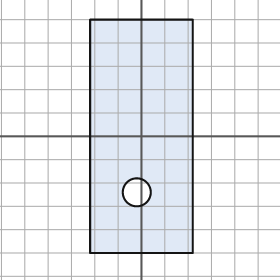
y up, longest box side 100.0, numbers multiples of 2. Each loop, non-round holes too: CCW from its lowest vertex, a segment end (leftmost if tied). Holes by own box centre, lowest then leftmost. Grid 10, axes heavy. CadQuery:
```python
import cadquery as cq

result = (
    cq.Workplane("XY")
    .moveTo(-22.0, -50.0)
    .lineTo(22.0, -50.0)
    .lineTo(22.0, 50.0)
    .lineTo(-22.0, 50.0)
    .close()
    .moveTo(-2.0, -24.0)
    .circle(6.0)
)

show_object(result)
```